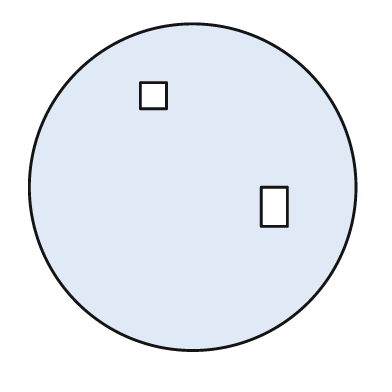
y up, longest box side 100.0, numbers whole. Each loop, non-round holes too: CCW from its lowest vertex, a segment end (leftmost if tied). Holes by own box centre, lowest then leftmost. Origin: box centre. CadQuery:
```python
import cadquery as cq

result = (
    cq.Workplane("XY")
    .moveTo(0.0, 0.0)
    .circle(50.0)
    .moveTo(21.0, -12.0)
    .lineTo(29.0, -12.0)
    .lineTo(29.0, 0.0)
    .lineTo(21.0, 0.0)
    .close()
    .moveTo(-16.0, 24.0)
    .lineTo(-8.0, 24.0)
    .lineTo(-8.0, 32.0)
    .lineTo(-16.0, 32.0)
    .close()
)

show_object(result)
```